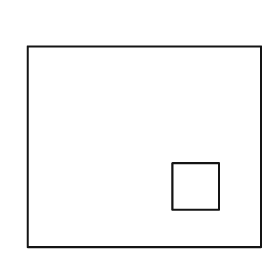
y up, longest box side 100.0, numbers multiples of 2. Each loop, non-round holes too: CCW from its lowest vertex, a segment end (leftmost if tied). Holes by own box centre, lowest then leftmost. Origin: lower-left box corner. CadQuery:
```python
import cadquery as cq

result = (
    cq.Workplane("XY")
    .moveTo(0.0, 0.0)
    .lineTo(100.0, 0.0)
    .lineTo(100.0, 86.0)
    .lineTo(0.0, 86.0)
    .close()
    .moveTo(62.0, 16.0)
    .lineTo(82.0, 16.0)
    .lineTo(82.0, 36.0)
    .lineTo(62.0, 36.0)
    .close()
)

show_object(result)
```